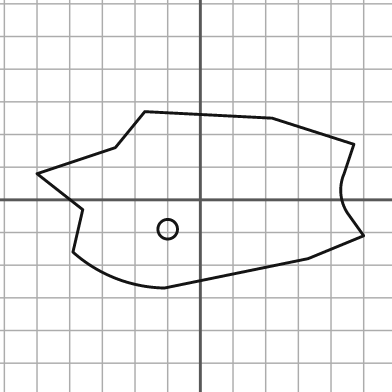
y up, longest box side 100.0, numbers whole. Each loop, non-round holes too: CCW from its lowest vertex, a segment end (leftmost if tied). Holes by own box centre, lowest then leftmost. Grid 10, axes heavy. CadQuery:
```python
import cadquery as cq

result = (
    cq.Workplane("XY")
    .moveTo(-11.0, -27.0)
    .lineTo(33.0, -18.0)
    .lineTo(50.0, -11.0)
    .lineTo(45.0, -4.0)
    .threePointArc((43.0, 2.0), (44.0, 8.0))
    .lineTo(47.0, 17.0)
    .lineTo(22.0, 25.0)
    .lineTo(-17.0, 27.0)
    .lineTo(-26.0, 16.0)
    .lineTo(-50.0, 8.0)
    .lineTo(-36.0, -3.0)
    .lineTo(-39.0, -16.0)
    .threePointArc((-26.0, -24.0), (-11.0, -27.0))
    .close()
    .moveTo(-10.0, -9.0)
    .circle(3.0)
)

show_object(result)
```